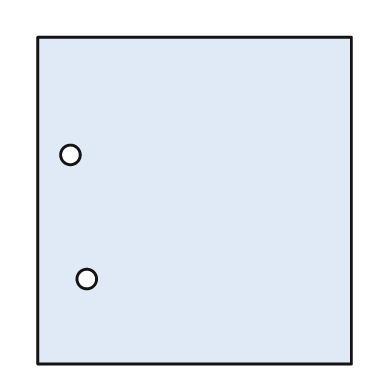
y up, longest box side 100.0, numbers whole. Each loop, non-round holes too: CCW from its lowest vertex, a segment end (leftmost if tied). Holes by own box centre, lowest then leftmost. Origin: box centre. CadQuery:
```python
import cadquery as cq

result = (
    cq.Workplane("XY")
    .moveTo(-48.0, -50.0)
    .lineTo(48.0, -50.0)
    .lineTo(48.0, 50.0)
    .lineTo(-48.0, 50.0)
    .close()
    .moveTo(-33.0, -24.0)
    .circle(3.0)
    .moveTo(-38.0, 14.0)
    .circle(3.0)
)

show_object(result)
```